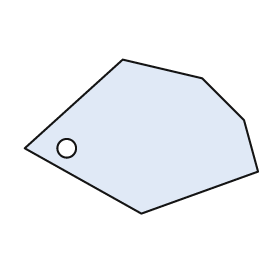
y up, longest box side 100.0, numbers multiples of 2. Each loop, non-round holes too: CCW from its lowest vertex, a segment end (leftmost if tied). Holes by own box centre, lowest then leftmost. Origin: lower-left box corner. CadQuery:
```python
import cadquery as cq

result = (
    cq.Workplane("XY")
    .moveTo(50.0, 0.0)
    .lineTo(100.0, 18.0)
    .lineTo(94.0, 40.0)
    .lineTo(76.0, 58.0)
    .lineTo(42.0, 66.0)
    .lineTo(0.0, 28.0)
    .close()
    .moveTo(18.0, 28.0)
    .circle(4.0)
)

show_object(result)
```